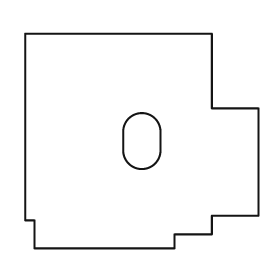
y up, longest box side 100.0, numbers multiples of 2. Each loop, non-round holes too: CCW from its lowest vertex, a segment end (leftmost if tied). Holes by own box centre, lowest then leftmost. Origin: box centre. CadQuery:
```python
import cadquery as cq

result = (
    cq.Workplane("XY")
    .moveTo(-46.0, -46.0)
    .lineTo(14.0, -46.0)
    .lineTo(14.0, -40.0)
    .lineTo(30.0, -40.0)
    .lineTo(30.0, -32.0)
    .lineTo(50.0, -32.0)
    .lineTo(50.0, 14.0)
    .lineTo(30.0, 14.0)
    .lineTo(30.0, 46.0)
    .lineTo(-50.0, 46.0)
    .lineTo(-50.0, -34.0)
    .lineTo(-46.0, -34.0)
    .close()
    .moveTo(-8.0, -4.0)
    .threePointArc((0.0, -12.0), (8.0, -4.0))
    .lineTo(8.0, 4.0)
    .threePointArc((0.0, 12.0), (-8.0, 4.0))
    .close()
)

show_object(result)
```